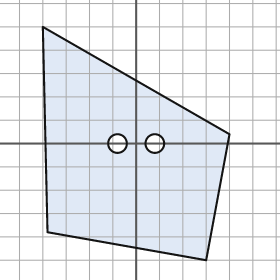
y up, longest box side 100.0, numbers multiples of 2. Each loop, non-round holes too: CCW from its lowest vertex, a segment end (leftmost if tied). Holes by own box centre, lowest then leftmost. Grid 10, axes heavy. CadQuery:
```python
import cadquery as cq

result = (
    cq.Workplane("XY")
    .moveTo(30.0, -50.0)
    .lineTo(40.0, 4.0)
    .lineTo(-40.0, 50.0)
    .lineTo(-38.0, -38.0)
    .close()
    .moveTo(-8.0, 0.0)
    .circle(4.0)
    .moveTo(8.0, 0.0)
    .circle(4.0)
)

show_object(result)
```